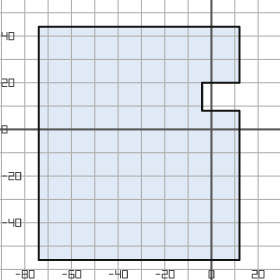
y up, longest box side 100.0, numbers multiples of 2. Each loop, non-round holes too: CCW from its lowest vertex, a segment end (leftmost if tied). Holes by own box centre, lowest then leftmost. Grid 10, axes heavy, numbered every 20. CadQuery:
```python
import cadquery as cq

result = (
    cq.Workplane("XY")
    .moveTo(-74.0, -56.0)
    .lineTo(12.0, -56.0)
    .lineTo(12.0, 8.0)
    .lineTo(-4.0, 8.0)
    .lineTo(-4.0, 20.0)
    .lineTo(12.0, 20.0)
    .lineTo(12.0, 44.0)
    .lineTo(-74.0, 44.0)
    .close()
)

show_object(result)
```